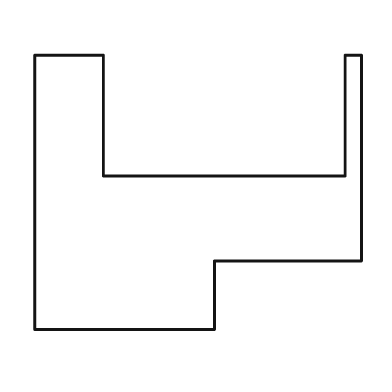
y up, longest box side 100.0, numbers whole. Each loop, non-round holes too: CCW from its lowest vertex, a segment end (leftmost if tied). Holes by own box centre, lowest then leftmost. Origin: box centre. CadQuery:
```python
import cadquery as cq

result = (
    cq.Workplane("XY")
    .moveTo(-50.0, -42.0)
    .lineTo(5.0, -42.0)
    .lineTo(5.0, -21.0)
    .lineTo(50.0, -21.0)
    .lineTo(50.0, 42.0)
    .lineTo(45.0, 42.0)
    .lineTo(45.0, 5.0)
    .lineTo(-29.0, 5.0)
    .lineTo(-29.0, 42.0)
    .lineTo(-50.0, 42.0)
    .close()
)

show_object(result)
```